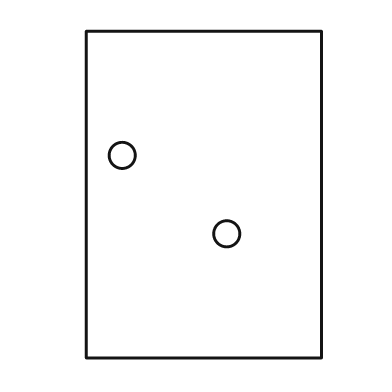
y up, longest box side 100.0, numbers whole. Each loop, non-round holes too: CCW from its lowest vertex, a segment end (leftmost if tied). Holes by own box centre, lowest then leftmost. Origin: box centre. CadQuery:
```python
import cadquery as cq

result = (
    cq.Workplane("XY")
    .moveTo(-36.0, -50.0)
    .lineTo(36.0, -50.0)
    .lineTo(36.0, 50.0)
    .lineTo(-36.0, 50.0)
    .close()
    .moveTo(7.0, -12.0)
    .circle(4.0)
    .moveTo(-25.0, 12.0)
    .circle(4.0)
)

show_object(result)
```